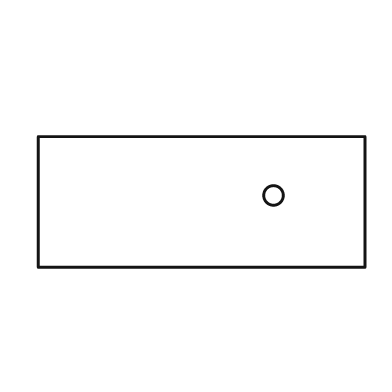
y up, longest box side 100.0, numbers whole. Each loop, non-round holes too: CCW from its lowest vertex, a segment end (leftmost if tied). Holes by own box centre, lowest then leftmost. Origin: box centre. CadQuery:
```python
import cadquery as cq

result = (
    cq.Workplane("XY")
    .moveTo(-50.0, -20.0)
    .lineTo(50.0, -20.0)
    .lineTo(50.0, 20.0)
    .lineTo(-50.0, 20.0)
    .close()
    .moveTo(22.0, 2.0)
    .circle(3.0)
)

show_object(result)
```